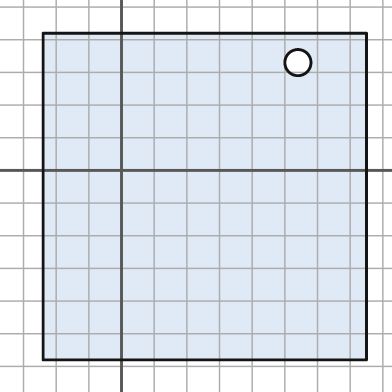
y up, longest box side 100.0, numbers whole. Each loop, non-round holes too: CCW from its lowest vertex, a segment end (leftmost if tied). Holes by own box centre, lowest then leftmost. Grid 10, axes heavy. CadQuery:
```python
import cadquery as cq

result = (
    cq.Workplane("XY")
    .moveTo(-24.0, -58.0)
    .lineTo(75.0, -58.0)
    .lineTo(75.0, 42.0)
    .lineTo(-24.0, 42.0)
    .close()
    .moveTo(54.0, 33.0)
    .circle(4.0)
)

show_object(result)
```